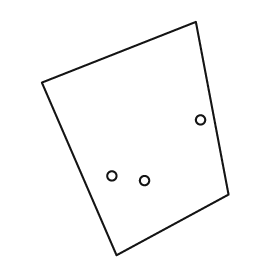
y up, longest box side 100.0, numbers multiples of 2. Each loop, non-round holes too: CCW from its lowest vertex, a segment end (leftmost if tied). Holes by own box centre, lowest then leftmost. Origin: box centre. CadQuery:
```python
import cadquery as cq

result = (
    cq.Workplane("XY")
    .moveTo(-8.0, -50.0)
    .lineTo(40.0, -24.0)
    .lineTo(26.0, 50.0)
    .lineTo(-40.0, 24.0)
    .close()
    .moveTo(4.0, -18.0)
    .circle(2.0)
    .moveTo(-10.0, -16.0)
    .circle(2.0)
    .moveTo(28.0, 8.0)
    .circle(2.0)
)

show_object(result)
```